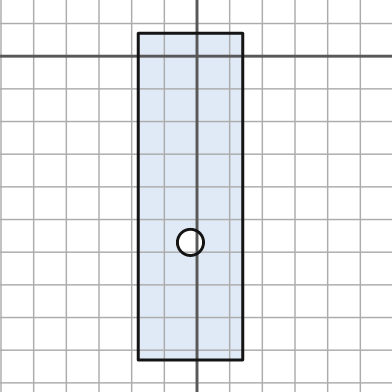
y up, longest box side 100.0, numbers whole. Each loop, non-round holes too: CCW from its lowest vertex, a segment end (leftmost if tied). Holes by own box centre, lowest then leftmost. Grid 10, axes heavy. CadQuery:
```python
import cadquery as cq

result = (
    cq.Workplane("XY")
    .moveTo(-18.0, -93.0)
    .lineTo(14.0, -93.0)
    .lineTo(14.0, 7.0)
    .lineTo(-18.0, 7.0)
    .close()
    .moveTo(-2.0, -57.0)
    .circle(4.0)
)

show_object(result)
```